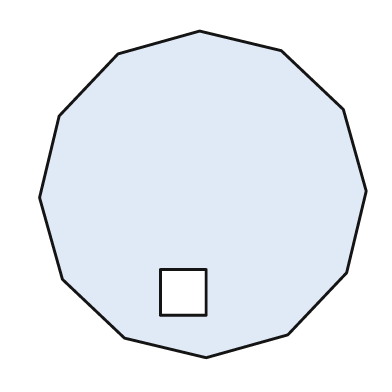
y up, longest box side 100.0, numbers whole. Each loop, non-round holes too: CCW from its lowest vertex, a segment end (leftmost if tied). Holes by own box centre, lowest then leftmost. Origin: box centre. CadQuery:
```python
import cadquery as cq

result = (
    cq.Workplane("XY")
    .moveTo(1.0, -50.0)
    .lineTo(26.0, -43.0)
    .lineTo(44.0, -24.0)
    .lineTo(50.0, 1.0)
    .lineTo(43.0, 26.0)
    .lineTo(24.0, 44.0)
    .lineTo(-1.0, 50.0)
    .lineTo(-26.0, 43.0)
    .lineTo(-44.0, 24.0)
    .lineTo(-50.0, -1.0)
    .lineTo(-43.0, -26.0)
    .lineTo(-24.0, -44.0)
    .close()
    .moveTo(-13.0, -37.0)
    .lineTo(1.0, -37.0)
    .lineTo(1.0, -23.0)
    .lineTo(-13.0, -23.0)
    .close()
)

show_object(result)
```